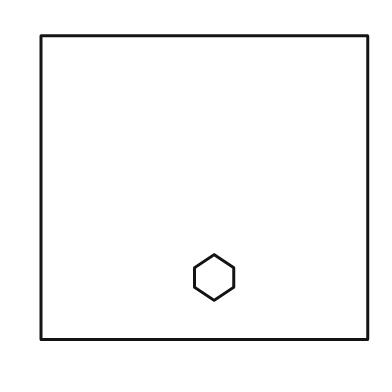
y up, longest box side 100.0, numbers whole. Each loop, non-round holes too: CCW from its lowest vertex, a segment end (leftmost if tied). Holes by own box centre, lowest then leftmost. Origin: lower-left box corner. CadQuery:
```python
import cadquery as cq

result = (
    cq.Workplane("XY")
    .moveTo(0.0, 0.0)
    .lineTo(100.0, 0.0)
    .lineTo(100.0, 93.0)
    .lineTo(0.0, 93.0)
    .close()
    .moveTo(53.0, 12.0)
    .lineTo(59.0, 16.0)
    .lineTo(59.0, 22.0)
    .lineTo(53.0, 26.0)
    .lineTo(47.0, 22.0)
    .lineTo(47.0, 16.0)
    .close()
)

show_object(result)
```